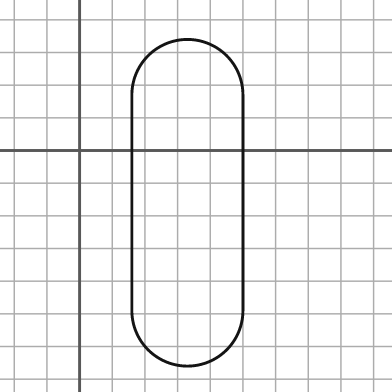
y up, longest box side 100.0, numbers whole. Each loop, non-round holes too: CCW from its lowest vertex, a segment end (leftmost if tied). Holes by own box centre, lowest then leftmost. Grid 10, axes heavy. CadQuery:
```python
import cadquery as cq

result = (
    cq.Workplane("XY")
    .moveTo(16.0, -49.0)
    .threePointArc((33.0, -66.0), (50.0, -49.0))
    .lineTo(50.0, 17.0)
    .threePointArc((33.0, 34.0), (16.0, 17.0))
    .close()
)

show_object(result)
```